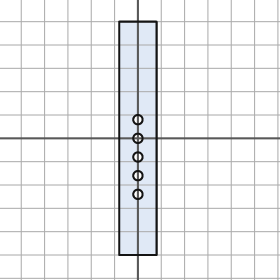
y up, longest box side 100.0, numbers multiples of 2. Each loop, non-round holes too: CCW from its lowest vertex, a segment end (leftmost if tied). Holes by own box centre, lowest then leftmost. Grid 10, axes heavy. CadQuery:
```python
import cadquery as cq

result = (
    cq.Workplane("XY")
    .moveTo(-8.0, -50.0)
    .lineTo(8.0, -50.0)
    .lineTo(8.0, 50.0)
    .lineTo(-8.0, 50.0)
    .close()
    .moveTo(0.0, -24.0)
    .circle(2.0)
    .moveTo(0.0, -16.0)
    .circle(2.0)
    .moveTo(0.0, -8.0)
    .circle(2.0)
    .moveTo(0.0, 0.0)
    .circle(2.0)
    .moveTo(0.0, 8.0)
    .circle(2.0)
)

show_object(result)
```